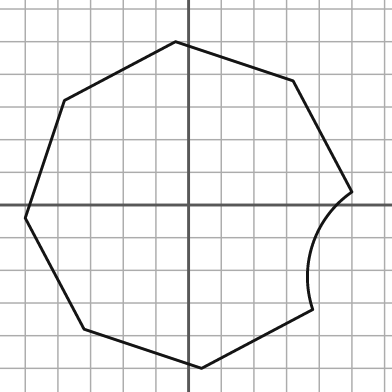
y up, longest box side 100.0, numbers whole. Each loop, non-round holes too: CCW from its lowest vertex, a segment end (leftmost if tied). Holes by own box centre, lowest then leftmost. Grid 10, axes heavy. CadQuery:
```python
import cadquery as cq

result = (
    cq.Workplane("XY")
    .moveTo(4.0, -50.0)
    .lineTo(38.0, -32.0)
    .threePointArc((38.0, -12.0), (50.0, 4.0))
    .lineTo(32.0, 38.0)
    .lineTo(-4.0, 50.0)
    .lineTo(-38.0, 32.0)
    .lineTo(-50.0, -4.0)
    .lineTo(-32.0, -38.0)
    .close()
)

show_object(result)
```